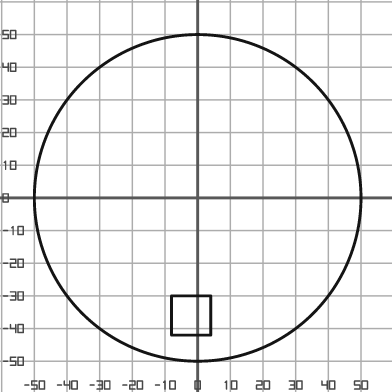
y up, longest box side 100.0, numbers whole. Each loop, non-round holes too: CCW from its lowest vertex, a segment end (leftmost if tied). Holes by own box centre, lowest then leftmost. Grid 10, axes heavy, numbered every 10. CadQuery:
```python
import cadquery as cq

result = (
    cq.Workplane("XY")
    .moveTo(0.0, 0.0)
    .circle(50.0)
    .moveTo(-8.0, -42.0)
    .lineTo(4.0, -42.0)
    .lineTo(4.0, -30.0)
    .lineTo(-8.0, -30.0)
    .close()
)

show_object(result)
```